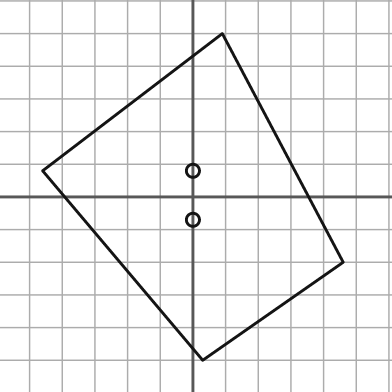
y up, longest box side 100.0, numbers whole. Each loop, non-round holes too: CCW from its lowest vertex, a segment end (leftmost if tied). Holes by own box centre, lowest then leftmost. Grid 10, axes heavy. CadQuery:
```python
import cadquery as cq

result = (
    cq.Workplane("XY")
    .moveTo(3.0, -50.0)
    .lineTo(46.0, -20.0)
    .lineTo(9.0, 50.0)
    .lineTo(-46.0, 8.0)
    .close()
    .moveTo(0.0, -7.0)
    .circle(2.0)
    .moveTo(0.0, 8.0)
    .circle(2.0)
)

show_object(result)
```